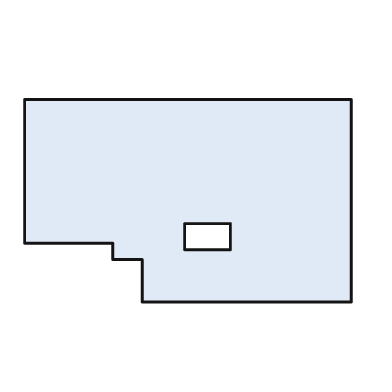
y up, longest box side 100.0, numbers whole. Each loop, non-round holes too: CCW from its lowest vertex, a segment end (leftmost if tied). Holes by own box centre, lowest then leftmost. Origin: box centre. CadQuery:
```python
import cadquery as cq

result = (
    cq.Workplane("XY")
    .moveTo(-14.0, -31.0)
    .lineTo(50.0, -31.0)
    .lineTo(50.0, 31.0)
    .lineTo(-50.0, 31.0)
    .lineTo(-50.0, -13.0)
    .lineTo(-23.0, -13.0)
    .lineTo(-23.0, -18.0)
    .lineTo(-14.0, -18.0)
    .close()
    .moveTo(-1.0, -15.0)
    .lineTo(13.0, -15.0)
    .lineTo(13.0, -7.0)
    .lineTo(-1.0, -7.0)
    .close()
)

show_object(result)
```